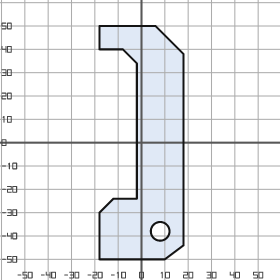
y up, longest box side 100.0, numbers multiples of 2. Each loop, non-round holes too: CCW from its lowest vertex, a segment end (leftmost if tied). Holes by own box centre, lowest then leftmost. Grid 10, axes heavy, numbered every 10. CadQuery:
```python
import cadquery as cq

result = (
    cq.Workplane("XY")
    .moveTo(-18.0, -50.0)
    .lineTo(10.0, -50.0)
    .lineTo(18.0, -44.0)
    .lineTo(18.0, 38.0)
    .lineTo(6.0, 50.0)
    .lineTo(-18.0, 50.0)
    .lineTo(-18.0, 40.0)
    .lineTo(-8.0, 40.0)
    .lineTo(-2.0, 34.0)
    .lineTo(-2.0, -24.0)
    .lineTo(-12.0, -24.0)
    .lineTo(-18.0, -30.0)
    .close()
    .moveTo(8.0, -38.0)
    .circle(4.0)
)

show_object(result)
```